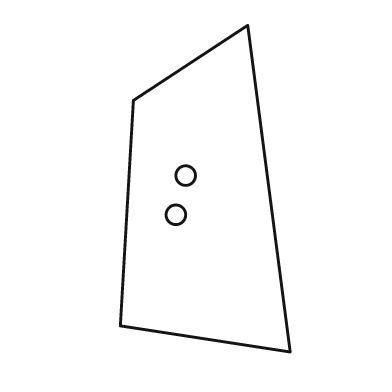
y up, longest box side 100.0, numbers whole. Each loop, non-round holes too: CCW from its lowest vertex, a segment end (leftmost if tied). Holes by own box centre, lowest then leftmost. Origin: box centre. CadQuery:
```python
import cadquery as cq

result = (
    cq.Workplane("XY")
    .moveTo(26.0, -50.0)
    .lineTo(13.0, 50.0)
    .lineTo(-22.0, 27.0)
    .lineTo(-26.0, -42.0)
    .close()
    .moveTo(-9.0, -8.0)
    .circle(3.0)
    .moveTo(-6.0, 4.0)
    .circle(3.0)
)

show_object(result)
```